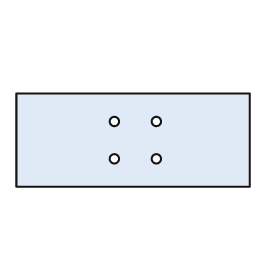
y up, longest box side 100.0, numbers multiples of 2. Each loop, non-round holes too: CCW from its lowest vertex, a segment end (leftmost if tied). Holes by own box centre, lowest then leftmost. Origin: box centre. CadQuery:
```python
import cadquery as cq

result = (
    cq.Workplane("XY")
    .moveTo(-50.0, -20.0)
    .lineTo(50.0, -20.0)
    .lineTo(50.0, 20.0)
    .lineTo(-50.0, 20.0)
    .close()
    .moveTo(-8.0, -8.0)
    .circle(2.0)
    .moveTo(10.0, -8.0)
    .circle(2.0)
    .moveTo(-8.0, 8.0)
    .circle(2.0)
    .moveTo(10.0, 8.0)
    .circle(2.0)
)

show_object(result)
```